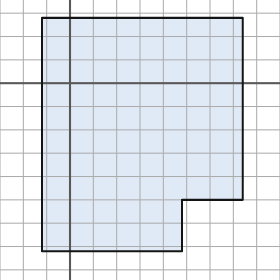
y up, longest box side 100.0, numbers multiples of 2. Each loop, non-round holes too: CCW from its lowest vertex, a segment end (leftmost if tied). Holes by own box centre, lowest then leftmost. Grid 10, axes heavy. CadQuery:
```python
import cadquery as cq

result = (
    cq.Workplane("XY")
    .moveTo(-12.0, -72.0)
    .lineTo(48.0, -72.0)
    .lineTo(48.0, -50.0)
    .lineTo(74.0, -50.0)
    .lineTo(74.0, 28.0)
    .lineTo(-12.0, 28.0)
    .close()
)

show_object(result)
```